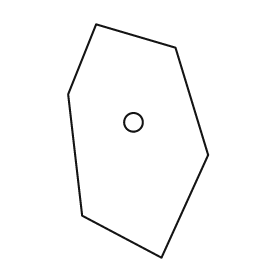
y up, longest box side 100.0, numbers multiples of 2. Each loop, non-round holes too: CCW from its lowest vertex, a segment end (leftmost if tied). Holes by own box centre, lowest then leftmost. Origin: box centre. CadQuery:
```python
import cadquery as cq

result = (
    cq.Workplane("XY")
    .moveTo(10.0, -50.0)
    .lineTo(30.0, -6.0)
    .lineTo(16.0, 40.0)
    .lineTo(-18.0, 50.0)
    .lineTo(-30.0, 20.0)
    .lineTo(-24.0, -32.0)
    .close()
    .moveTo(-2.0, 8.0)
    .circle(4.0)
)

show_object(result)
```